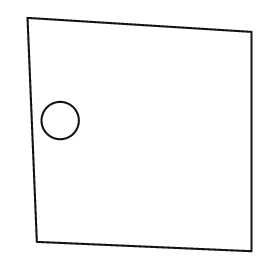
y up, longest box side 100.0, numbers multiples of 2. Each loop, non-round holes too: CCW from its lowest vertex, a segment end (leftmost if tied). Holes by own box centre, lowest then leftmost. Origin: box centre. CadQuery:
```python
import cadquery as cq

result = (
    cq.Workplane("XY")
    .moveTo(48.0, -50.0)
    .lineTo(48.0, 44.0)
    .lineTo(-48.0, 50.0)
    .lineTo(-44.0, -46.0)
    .close()
    .moveTo(-34.0, 6.0)
    .circle(8.0)
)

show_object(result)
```